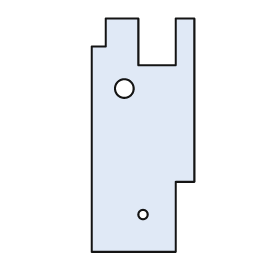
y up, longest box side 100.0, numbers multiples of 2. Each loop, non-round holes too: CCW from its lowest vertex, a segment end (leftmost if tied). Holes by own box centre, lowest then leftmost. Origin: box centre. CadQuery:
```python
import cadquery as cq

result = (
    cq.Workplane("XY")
    .moveTo(-22.0, -50.0)
    .lineTo(14.0, -50.0)
    .lineTo(14.0, -20.0)
    .lineTo(22.0, -20.0)
    .lineTo(22.0, 50.0)
    .lineTo(14.0, 50.0)
    .lineTo(14.0, 30.0)
    .lineTo(-2.0, 30.0)
    .lineTo(-2.0, 50.0)
    .lineTo(-16.0, 50.0)
    .lineTo(-16.0, 38.0)
    .lineTo(-22.0, 38.0)
    .close()
    .moveTo(0.0, -34.0)
    .circle(2.0)
    .moveTo(-8.0, 20.0)
    .circle(4.0)
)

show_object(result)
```